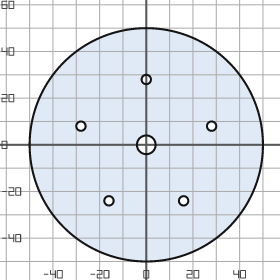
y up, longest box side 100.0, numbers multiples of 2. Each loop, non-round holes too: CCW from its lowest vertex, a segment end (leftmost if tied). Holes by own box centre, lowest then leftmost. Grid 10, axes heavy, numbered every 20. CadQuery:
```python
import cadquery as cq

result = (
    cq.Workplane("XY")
    .moveTo(0.0, 0.0)
    .circle(50.0)
    .moveTo(-16.0, -24.0)
    .circle(2.0)
    .moveTo(16.0, -24.0)
    .circle(2.0)
    .moveTo(0.0, 0.0)
    .circle(4.0)
    .moveTo(-28.0, 8.0)
    .circle(2.0)
    .moveTo(28.0, 8.0)
    .circle(2.0)
    .moveTo(0.0, 28.0)
    .circle(2.0)
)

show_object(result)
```